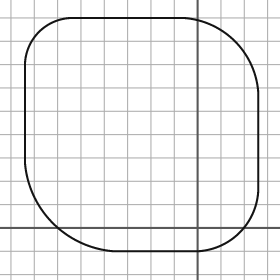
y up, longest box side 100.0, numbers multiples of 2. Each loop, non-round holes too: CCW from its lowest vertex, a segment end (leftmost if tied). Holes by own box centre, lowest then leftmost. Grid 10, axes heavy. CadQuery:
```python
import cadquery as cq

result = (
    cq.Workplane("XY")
    .moveTo(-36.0, -10.0)
    .lineTo(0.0, -10.0)
    .threePointArc((18.0, -2.0), (26.0, 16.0))
    .lineTo(26.0, 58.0)
    .threePointArc((16.0, 80.0), (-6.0, 90.0))
    .lineTo(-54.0, 90.0)
    .threePointArc((-68.0, 84.0), (-74.0, 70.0))
    .lineTo(-74.0, 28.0)
    .threePointArc((-62.0, 2.0), (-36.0, -10.0))
    .close()
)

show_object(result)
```